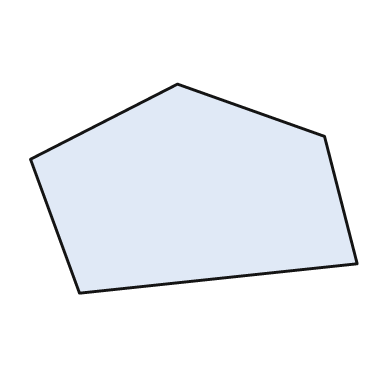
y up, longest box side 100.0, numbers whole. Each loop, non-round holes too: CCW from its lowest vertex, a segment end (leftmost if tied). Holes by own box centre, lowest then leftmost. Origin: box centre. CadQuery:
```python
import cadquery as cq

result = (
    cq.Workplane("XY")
    .moveTo(-35.0, -32.0)
    .lineTo(50.0, -23.0)
    .lineTo(40.0, 16.0)
    .lineTo(-5.0, 32.0)
    .lineTo(-50.0, 9.0)
    .close()
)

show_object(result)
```